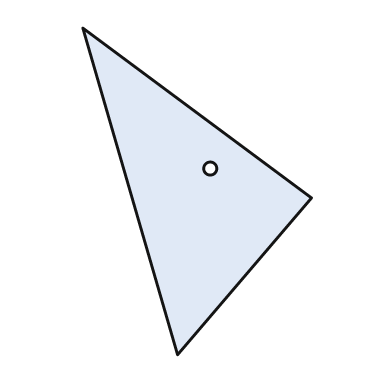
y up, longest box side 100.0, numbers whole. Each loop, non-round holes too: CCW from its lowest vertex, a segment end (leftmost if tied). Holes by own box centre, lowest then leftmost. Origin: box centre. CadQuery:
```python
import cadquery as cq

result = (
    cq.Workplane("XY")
    .moveTo(-6.0, -50.0)
    .lineTo(35.0, -2.0)
    .lineTo(-35.0, 50.0)
    .close()
    .moveTo(4.0, 7.0)
    .circle(2.0)
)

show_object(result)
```